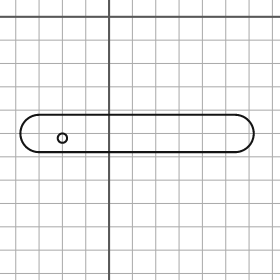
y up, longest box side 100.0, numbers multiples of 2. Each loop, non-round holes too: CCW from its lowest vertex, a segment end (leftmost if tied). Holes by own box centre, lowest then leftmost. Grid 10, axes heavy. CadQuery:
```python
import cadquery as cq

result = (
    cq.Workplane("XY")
    .moveTo(-30.0, -58.0)
    .lineTo(54.0, -58.0)
    .threePointArc((62.0, -50.0), (54.0, -42.0))
    .lineTo(-30.0, -42.0)
    .threePointArc((-38.0, -50.0), (-30.0, -58.0))
    .close()
    .moveTo(-20.0, -52.0)
    .circle(2.0)
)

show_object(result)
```